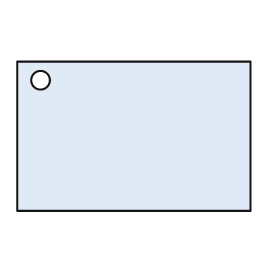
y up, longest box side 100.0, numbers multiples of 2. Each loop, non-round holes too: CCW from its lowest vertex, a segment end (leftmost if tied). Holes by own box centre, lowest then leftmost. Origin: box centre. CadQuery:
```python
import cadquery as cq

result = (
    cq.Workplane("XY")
    .moveTo(-50.0, -32.0)
    .lineTo(50.0, -32.0)
    .lineTo(50.0, 32.0)
    .lineTo(-50.0, 32.0)
    .close()
    .moveTo(-40.0, 24.0)
    .circle(4.0)
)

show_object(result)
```